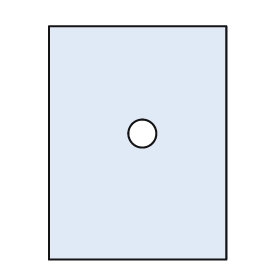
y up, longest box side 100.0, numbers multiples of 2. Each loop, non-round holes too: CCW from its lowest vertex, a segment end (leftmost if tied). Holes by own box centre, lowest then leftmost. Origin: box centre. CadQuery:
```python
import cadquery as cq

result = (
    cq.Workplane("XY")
    .moveTo(-38.0, -50.0)
    .lineTo(38.0, -50.0)
    .lineTo(38.0, 50.0)
    .lineTo(-38.0, 50.0)
    .close()
    .moveTo(2.0, 4.0)
    .circle(6.0)
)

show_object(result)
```